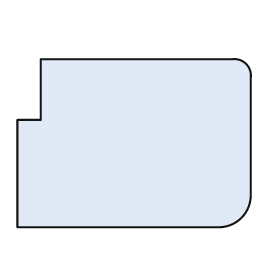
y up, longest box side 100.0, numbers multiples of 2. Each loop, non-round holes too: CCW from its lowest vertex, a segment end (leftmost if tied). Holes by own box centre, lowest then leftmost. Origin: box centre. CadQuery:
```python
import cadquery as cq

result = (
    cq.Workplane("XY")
    .moveTo(-50.0, -36.0)
    .lineTo(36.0, -36.0)
    .threePointArc((46.0, -32.0), (50.0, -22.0))
    .lineTo(50.0, 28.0)
    .threePointArc((48.0, 34.0), (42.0, 36.0))
    .lineTo(-40.0, 36.0)
    .lineTo(-40.0, 10.0)
    .lineTo(-50.0, 10.0)
    .close()
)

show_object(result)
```